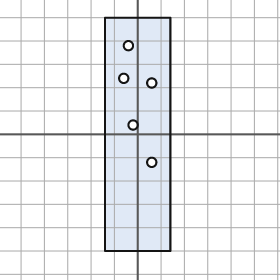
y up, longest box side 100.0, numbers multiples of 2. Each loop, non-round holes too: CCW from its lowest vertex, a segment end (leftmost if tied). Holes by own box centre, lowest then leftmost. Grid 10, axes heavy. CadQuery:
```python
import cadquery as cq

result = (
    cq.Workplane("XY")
    .moveTo(-14.0, -50.0)
    .lineTo(14.0, -50.0)
    .lineTo(14.0, 50.0)
    .lineTo(-14.0, 50.0)
    .close()
    .moveTo(6.0, -12.0)
    .circle(2.0)
    .moveTo(-2.0, 4.0)
    .circle(2.0)
    .moveTo(6.0, 22.0)
    .circle(2.0)
    .moveTo(-6.0, 24.0)
    .circle(2.0)
    .moveTo(-4.0, 38.0)
    .circle(2.0)
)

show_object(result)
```